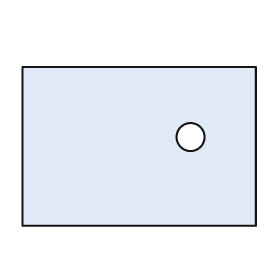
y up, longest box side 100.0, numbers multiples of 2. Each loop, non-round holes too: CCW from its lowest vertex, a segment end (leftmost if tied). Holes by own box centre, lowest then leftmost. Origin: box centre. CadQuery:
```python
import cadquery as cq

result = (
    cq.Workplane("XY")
    .moveTo(-50.0, -34.0)
    .lineTo(50.0, -34.0)
    .lineTo(50.0, 34.0)
    .lineTo(-50.0, 34.0)
    .close()
    .moveTo(22.0, 4.0)
    .circle(6.0)
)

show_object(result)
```